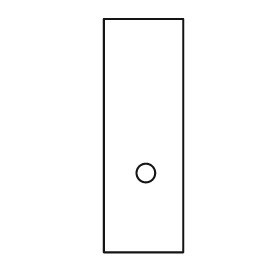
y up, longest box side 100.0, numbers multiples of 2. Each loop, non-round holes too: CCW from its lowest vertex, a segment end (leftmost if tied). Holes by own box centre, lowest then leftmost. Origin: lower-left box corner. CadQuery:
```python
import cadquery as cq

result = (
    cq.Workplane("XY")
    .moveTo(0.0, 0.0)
    .lineTo(34.0, 0.0)
    .lineTo(34.0, 100.0)
    .lineTo(0.0, 100.0)
    .close()
    .moveTo(18.0, 34.0)
    .circle(4.0)
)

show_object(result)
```